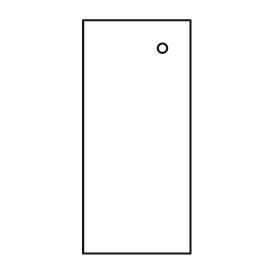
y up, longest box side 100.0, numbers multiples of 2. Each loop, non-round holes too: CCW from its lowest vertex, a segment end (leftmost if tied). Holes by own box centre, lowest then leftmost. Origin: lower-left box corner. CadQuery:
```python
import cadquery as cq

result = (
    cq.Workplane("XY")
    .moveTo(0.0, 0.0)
    .lineTo(46.0, 0.0)
    .lineTo(46.0, 100.0)
    .lineTo(0.0, 100.0)
    .close()
    .moveTo(34.0, 88.0)
    .circle(2.0)
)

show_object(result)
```